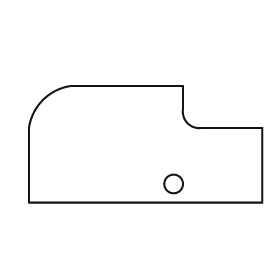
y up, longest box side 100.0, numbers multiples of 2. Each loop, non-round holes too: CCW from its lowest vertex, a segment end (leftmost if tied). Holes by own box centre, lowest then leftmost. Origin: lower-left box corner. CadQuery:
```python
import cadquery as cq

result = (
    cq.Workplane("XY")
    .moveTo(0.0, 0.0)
    .lineTo(100.0, 0.0)
    .lineTo(100.0, 32.0)
    .lineTo(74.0, 32.0)
    .threePointArc((68.0, 34.0), (66.0, 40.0))
    .lineTo(66.0, 50.0)
    .lineTo(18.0, 50.0)
    .threePointArc((6.0, 44.0), (0.0, 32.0))
    .close()
    .moveTo(62.0, 8.0)
    .circle(4.0)
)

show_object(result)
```